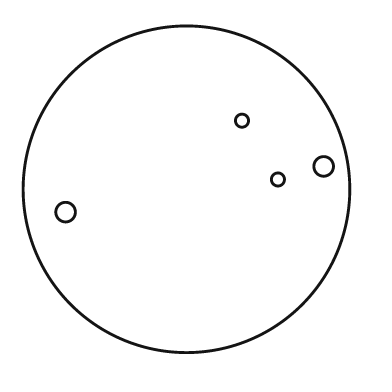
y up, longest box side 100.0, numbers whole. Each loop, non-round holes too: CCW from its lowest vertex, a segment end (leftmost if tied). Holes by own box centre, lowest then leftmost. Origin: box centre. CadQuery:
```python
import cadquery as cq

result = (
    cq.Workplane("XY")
    .moveTo(0.0, 0.0)
    .circle(50.0)
    .moveTo(-37.0, -7.0)
    .circle(3.0)
    .moveTo(28.0, 3.0)
    .circle(2.0)
    .moveTo(42.0, 7.0)
    .circle(3.0)
    .moveTo(17.0, 21.0)
    .circle(2.0)
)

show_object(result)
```